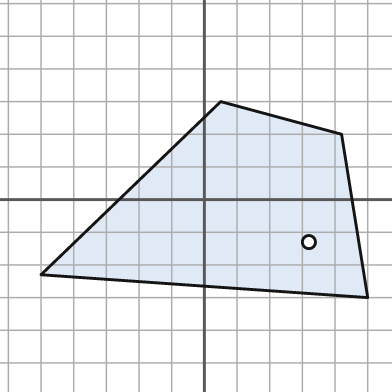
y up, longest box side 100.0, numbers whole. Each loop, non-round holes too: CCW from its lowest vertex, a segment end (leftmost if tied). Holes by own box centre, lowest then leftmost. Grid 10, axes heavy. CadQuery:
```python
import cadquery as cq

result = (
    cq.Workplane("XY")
    .moveTo(50.0, -30.0)
    .lineTo(42.0, 20.0)
    .lineTo(5.0, 30.0)
    .lineTo(-50.0, -23.0)
    .close()
    .moveTo(32.0, -13.0)
    .circle(2.0)
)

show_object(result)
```